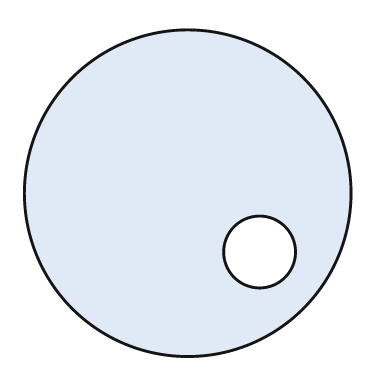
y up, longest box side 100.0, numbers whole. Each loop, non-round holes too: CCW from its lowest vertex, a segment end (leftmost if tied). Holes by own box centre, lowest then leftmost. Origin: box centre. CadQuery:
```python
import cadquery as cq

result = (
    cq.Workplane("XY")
    .moveTo(0.0, 0.0)
    .circle(50.0)
    .moveTo(22.0, -18.0)
    .circle(11.0)
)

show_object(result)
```